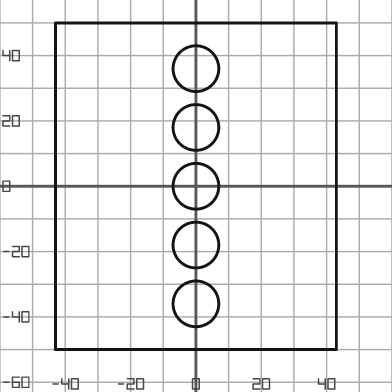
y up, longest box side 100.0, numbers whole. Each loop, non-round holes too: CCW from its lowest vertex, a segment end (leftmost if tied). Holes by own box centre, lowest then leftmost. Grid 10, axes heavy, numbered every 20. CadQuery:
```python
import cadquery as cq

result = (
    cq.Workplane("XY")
    .moveTo(-43.0, -50.0)
    .lineTo(43.0, -50.0)
    .lineTo(43.0, 50.0)
    .lineTo(-43.0, 50.0)
    .close()
    .moveTo(0.0, -36.0)
    .circle(7.0)
    .moveTo(0.0, -18.0)
    .circle(7.0)
    .moveTo(0.0, 0.0)
    .circle(7.0)
    .moveTo(0.0, 18.0)
    .circle(7.0)
    .moveTo(0.0, 36.0)
    .circle(7.0)
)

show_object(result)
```